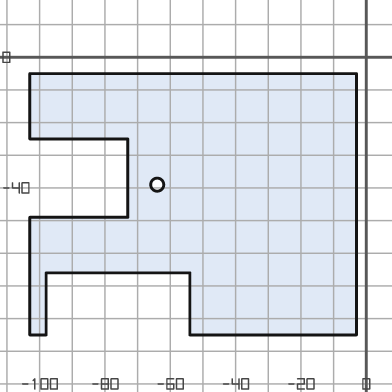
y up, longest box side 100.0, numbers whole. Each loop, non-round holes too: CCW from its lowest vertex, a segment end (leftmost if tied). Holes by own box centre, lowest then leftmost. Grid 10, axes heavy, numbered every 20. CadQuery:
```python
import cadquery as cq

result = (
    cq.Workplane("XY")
    .moveTo(-103.0, -85.0)
    .lineTo(-98.0, -85.0)
    .lineTo(-98.0, -66.0)
    .lineTo(-54.0, -66.0)
    .lineTo(-54.0, -85.0)
    .lineTo(-3.0, -85.0)
    .lineTo(-3.0, -5.0)
    .lineTo(-103.0, -5.0)
    .lineTo(-103.0, -25.0)
    .lineTo(-73.0, -25.0)
    .lineTo(-73.0, -49.0)
    .lineTo(-103.0, -49.0)
    .close()
    .moveTo(-64.0, -39.0)
    .circle(2.0)
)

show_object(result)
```